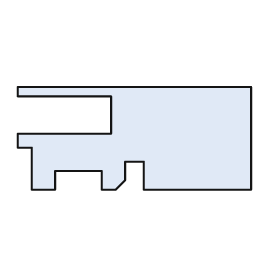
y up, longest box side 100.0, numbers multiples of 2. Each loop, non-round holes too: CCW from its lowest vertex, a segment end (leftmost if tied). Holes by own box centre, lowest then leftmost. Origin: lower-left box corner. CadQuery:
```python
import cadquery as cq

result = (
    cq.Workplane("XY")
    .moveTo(6.0, 0.0)
    .lineTo(16.0, 0.0)
    .lineTo(16.0, 8.0)
    .lineTo(36.0, 8.0)
    .lineTo(36.0, 0.0)
    .lineTo(42.0, 0.0)
    .lineTo(46.0, 4.0)
    .lineTo(46.0, 12.0)
    .lineTo(54.0, 12.0)
    .lineTo(54.0, 0.0)
    .lineTo(100.0, 0.0)
    .lineTo(100.0, 44.0)
    .lineTo(0.0, 44.0)
    .lineTo(0.0, 40.0)
    .lineTo(40.0, 40.0)
    .lineTo(40.0, 24.0)
    .lineTo(0.0, 24.0)
    .lineTo(0.0, 18.0)
    .lineTo(6.0, 18.0)
    .close()
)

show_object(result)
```